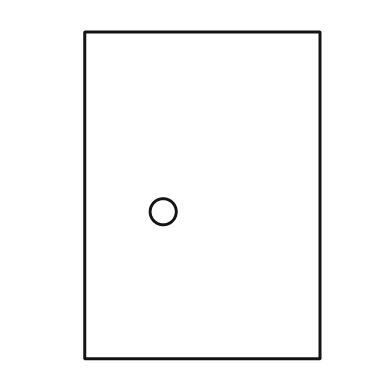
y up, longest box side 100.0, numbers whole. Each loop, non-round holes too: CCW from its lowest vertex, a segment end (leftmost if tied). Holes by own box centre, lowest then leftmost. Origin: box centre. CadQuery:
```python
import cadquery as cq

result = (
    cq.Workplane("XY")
    .moveTo(-36.0, -50.0)
    .lineTo(36.0, -50.0)
    .lineTo(36.0, 50.0)
    .lineTo(-36.0, 50.0)
    .close()
    .moveTo(-12.0, -5.0)
    .circle(4.0)
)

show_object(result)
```